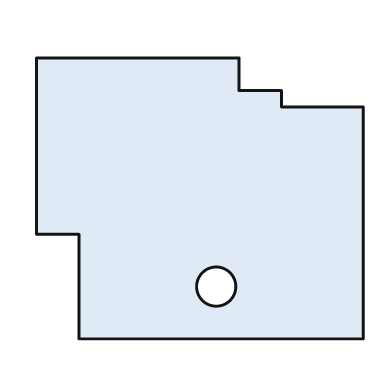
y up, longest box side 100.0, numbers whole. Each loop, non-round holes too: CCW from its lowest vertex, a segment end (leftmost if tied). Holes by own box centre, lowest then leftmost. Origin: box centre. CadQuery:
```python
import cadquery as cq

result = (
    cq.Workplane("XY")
    .moveTo(-37.0, -43.0)
    .lineTo(50.0, -43.0)
    .lineTo(50.0, 28.0)
    .lineTo(25.0, 28.0)
    .lineTo(25.0, 33.0)
    .lineTo(12.0, 33.0)
    .lineTo(12.0, 43.0)
    .lineTo(-50.0, 43.0)
    .lineTo(-50.0, -11.0)
    .lineTo(-37.0, -11.0)
    .close()
    .moveTo(5.0, -27.0)
    .circle(6.0)
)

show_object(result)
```